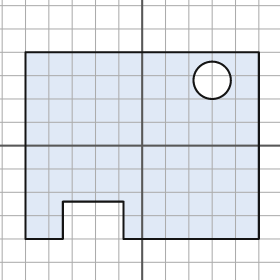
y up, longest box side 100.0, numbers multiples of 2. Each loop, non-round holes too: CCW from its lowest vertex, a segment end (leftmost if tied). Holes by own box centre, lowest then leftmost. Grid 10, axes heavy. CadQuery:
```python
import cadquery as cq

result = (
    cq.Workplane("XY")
    .moveTo(-50.0, -40.0)
    .lineTo(-34.0, -40.0)
    .lineTo(-34.0, -24.0)
    .lineTo(-8.0, -24.0)
    .lineTo(-8.0, -40.0)
    .lineTo(50.0, -40.0)
    .lineTo(50.0, 40.0)
    .lineTo(-50.0, 40.0)
    .close()
    .moveTo(30.0, 28.0)
    .circle(8.0)
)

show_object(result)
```